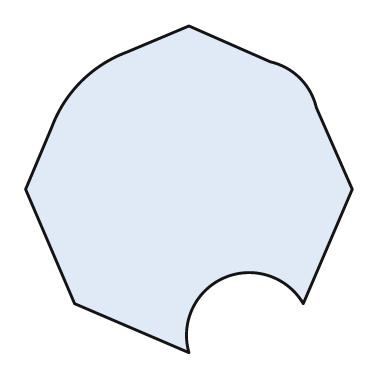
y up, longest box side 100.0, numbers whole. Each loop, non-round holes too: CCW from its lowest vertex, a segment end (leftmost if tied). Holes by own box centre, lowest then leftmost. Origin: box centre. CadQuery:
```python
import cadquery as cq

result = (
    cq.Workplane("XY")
    .moveTo(0.0, -50.0)
    .threePointArc((11.0, -27.0), (35.0, -35.0))
    .lineTo(50.0, 0.0)
    .lineTo(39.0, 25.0)
    .threePointArc((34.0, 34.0), (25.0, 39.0))
    .lineTo(0.0, 50.0)
    .lineTo(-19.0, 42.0)
    .threePointArc((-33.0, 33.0), (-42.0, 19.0))
    .lineTo(-50.0, 0.0)
    .lineTo(-35.0, -35.0)
    .close()
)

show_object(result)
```